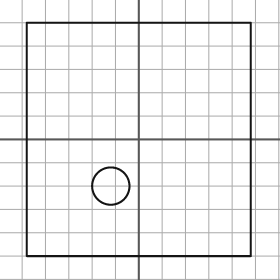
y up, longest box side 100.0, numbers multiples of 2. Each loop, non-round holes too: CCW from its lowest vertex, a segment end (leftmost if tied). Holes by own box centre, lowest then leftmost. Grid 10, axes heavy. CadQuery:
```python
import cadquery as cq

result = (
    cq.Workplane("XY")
    .moveTo(-48.0, -50.0)
    .lineTo(48.0, -50.0)
    .lineTo(48.0, 50.0)
    .lineTo(-48.0, 50.0)
    .close()
    .moveTo(-12.0, -20.0)
    .circle(8.0)
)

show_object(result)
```